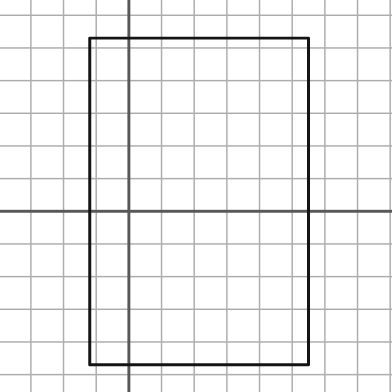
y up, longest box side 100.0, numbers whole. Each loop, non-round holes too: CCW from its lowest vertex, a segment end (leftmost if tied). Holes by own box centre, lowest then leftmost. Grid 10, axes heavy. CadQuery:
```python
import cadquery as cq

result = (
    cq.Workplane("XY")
    .moveTo(-12.0, -47.0)
    .lineTo(55.0, -47.0)
    .lineTo(55.0, 53.0)
    .lineTo(-12.0, 53.0)
    .close()
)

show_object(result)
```